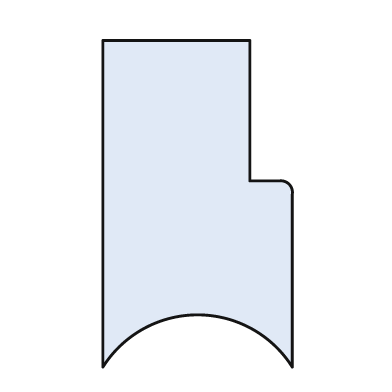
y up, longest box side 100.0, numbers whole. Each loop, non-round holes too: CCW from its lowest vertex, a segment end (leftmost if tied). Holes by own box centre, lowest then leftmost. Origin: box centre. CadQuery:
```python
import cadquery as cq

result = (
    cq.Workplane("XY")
    .moveTo(-29.0, -50.0)
    .threePointArc((0.0, -34.0), (29.0, -50.0))
    .lineTo(29.0, 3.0)
    .threePointArc((28.0, 6.0), (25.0, 7.0))
    .lineTo(16.0, 7.0)
    .lineTo(16.0, 50.0)
    .lineTo(-29.0, 50.0)
    .close()
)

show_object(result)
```